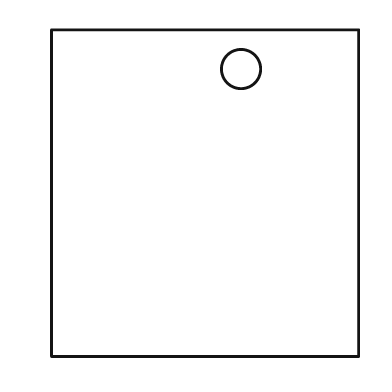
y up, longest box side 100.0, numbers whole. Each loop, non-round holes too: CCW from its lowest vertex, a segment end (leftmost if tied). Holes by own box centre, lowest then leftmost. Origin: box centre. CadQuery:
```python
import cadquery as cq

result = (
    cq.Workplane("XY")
    .moveTo(-47.0, -50.0)
    .lineTo(47.0, -50.0)
    .lineTo(47.0, 50.0)
    .lineTo(-47.0, 50.0)
    .close()
    .moveTo(11.0, 38.0)
    .circle(6.0)
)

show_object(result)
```